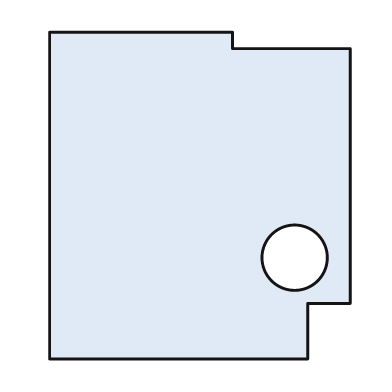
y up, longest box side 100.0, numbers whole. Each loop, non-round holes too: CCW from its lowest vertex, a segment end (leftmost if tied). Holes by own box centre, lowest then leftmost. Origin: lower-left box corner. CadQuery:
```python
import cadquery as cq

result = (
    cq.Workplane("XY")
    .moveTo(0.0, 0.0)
    .lineTo(79.0, 0.0)
    .lineTo(79.0, 17.0)
    .lineTo(92.0, 17.0)
    .lineTo(92.0, 95.0)
    .lineTo(56.0, 95.0)
    .lineTo(56.0, 100.0)
    .lineTo(0.0, 100.0)
    .close()
    .moveTo(75.0, 31.0)
    .circle(10.0)
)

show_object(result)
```